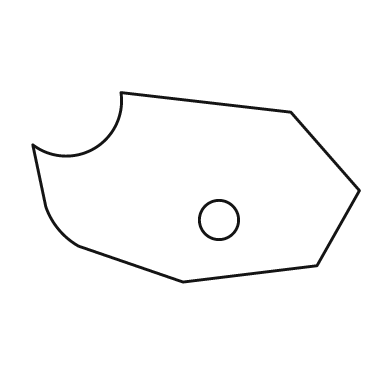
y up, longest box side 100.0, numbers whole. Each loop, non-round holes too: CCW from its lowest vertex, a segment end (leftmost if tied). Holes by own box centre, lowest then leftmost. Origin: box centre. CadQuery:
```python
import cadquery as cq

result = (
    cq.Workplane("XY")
    .moveTo(-4.0, -29.0)
    .lineTo(37.0, -24.0)
    .lineTo(50.0, -1.0)
    .lineTo(29.0, 23.0)
    .lineTo(-23.0, 29.0)
    .threePointArc((-31.0, 12.0), (-50.0, 13.0))
    .lineTo(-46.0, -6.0)
    .threePointArc((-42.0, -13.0), (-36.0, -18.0))
    .close()
    .moveTo(7.0, -10.0)
    .circle(6.0)
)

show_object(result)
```